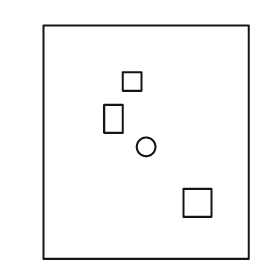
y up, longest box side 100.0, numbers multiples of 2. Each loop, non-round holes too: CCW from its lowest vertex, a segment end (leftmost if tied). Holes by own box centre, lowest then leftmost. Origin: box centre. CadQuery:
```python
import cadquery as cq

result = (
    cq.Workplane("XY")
    .moveTo(-44.0, -50.0)
    .lineTo(44.0, -50.0)
    .lineTo(44.0, 50.0)
    .lineTo(-44.0, 50.0)
    .close()
    .moveTo(16.0, -32.0)
    .lineTo(28.0, -32.0)
    .lineTo(28.0, -20.0)
    .lineTo(16.0, -20.0)
    .close()
    .moveTo(0.0, -2.0)
    .circle(4.0)
    .moveTo(-18.0, 4.0)
    .lineTo(-10.0, 4.0)
    .lineTo(-10.0, 16.0)
    .lineTo(-18.0, 16.0)
    .close()
    .moveTo(-10.0, 22.0)
    .lineTo(-2.0, 22.0)
    .lineTo(-2.0, 30.0)
    .lineTo(-10.0, 30.0)
    .close()
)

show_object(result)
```